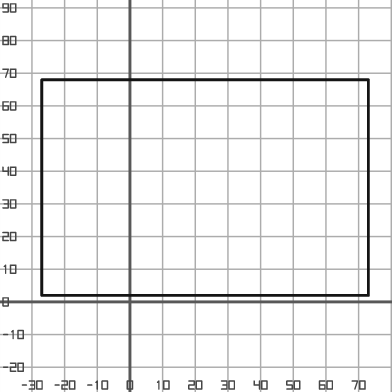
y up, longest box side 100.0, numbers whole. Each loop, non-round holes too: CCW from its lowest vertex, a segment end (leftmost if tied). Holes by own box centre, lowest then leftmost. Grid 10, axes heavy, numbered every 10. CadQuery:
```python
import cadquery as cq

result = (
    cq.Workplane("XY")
    .moveTo(-27.0, 2.0)
    .lineTo(73.0, 2.0)
    .lineTo(73.0, 68.0)
    .lineTo(-27.0, 68.0)
    .close()
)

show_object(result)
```